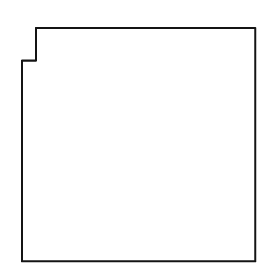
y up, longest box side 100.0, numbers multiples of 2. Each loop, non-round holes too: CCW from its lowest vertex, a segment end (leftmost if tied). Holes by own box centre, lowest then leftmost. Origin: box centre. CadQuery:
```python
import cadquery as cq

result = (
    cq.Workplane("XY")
    .moveTo(-50.0, -50.0)
    .lineTo(50.0, -50.0)
    .lineTo(50.0, 50.0)
    .lineTo(-44.0, 50.0)
    .lineTo(-44.0, 36.0)
    .lineTo(-50.0, 36.0)
    .close()
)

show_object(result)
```